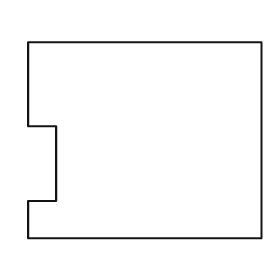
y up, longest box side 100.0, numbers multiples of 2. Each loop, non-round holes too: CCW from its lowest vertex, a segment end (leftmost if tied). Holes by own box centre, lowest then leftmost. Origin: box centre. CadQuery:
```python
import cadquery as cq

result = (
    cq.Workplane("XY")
    .moveTo(-50.0, -42.0)
    .lineTo(50.0, -42.0)
    .lineTo(50.0, 42.0)
    .lineTo(-50.0, 42.0)
    .lineTo(-50.0, 6.0)
    .lineTo(-38.0, 6.0)
    .lineTo(-38.0, -26.0)
    .lineTo(-50.0, -26.0)
    .close()
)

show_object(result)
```